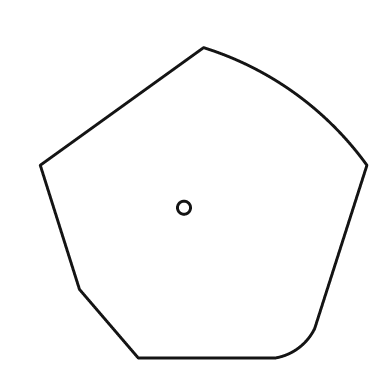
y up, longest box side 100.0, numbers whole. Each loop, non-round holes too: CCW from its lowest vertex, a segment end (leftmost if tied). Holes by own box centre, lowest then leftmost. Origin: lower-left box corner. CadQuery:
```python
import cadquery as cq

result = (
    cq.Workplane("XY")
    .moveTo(30.0, 0.0)
    .lineTo(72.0, 0.0)
    .threePointArc((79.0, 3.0), (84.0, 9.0))
    .lineTo(100.0, 59.0)
    .threePointArc((78.0, 81.0), (50.0, 95.0))
    .lineTo(0.0, 59.0)
    .lineTo(12.0, 21.0)
    .close()
    .moveTo(44.0, 46.0)
    .circle(2.0)
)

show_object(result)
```